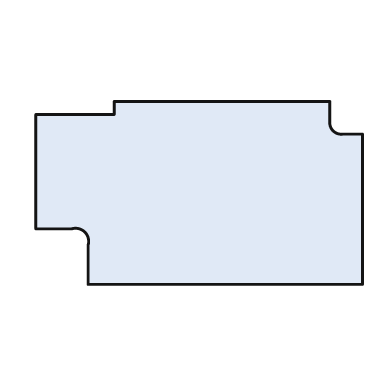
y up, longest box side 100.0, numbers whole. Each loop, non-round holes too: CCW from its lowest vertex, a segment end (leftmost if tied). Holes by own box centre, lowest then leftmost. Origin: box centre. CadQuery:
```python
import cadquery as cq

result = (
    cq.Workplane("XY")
    .moveTo(-34.0, -28.0)
    .lineTo(50.0, -28.0)
    .lineTo(50.0, 18.0)
    .lineTo(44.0, 18.0)
    .threePointArc((41.0, 19.0), (40.0, 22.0))
    .lineTo(40.0, 28.0)
    .lineTo(-26.0, 28.0)
    .lineTo(-26.0, 24.0)
    .lineTo(-50.0, 24.0)
    .lineTo(-50.0, -11.0)
    .lineTo(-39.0, -11.0)
    .threePointArc((-35.0, -12.0), (-34.0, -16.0))
    .close()
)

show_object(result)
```